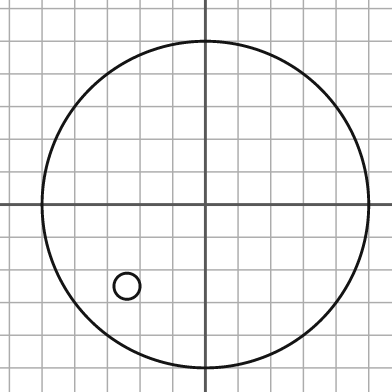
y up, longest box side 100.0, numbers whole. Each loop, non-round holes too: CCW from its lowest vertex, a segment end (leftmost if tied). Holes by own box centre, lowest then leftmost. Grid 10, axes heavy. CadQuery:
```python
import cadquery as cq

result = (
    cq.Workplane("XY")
    .moveTo(0.0, 0.0)
    .circle(50.0)
    .moveTo(-24.0, -25.0)
    .circle(4.0)
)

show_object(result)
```